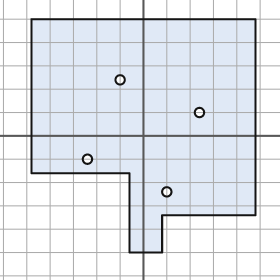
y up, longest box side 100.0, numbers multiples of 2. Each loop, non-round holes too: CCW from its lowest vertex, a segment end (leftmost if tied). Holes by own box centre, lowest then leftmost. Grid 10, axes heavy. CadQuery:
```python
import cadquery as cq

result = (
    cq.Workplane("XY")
    .moveTo(-6.0, -50.0)
    .lineTo(8.0, -50.0)
    .lineTo(8.0, -34.0)
    .lineTo(48.0, -34.0)
    .lineTo(48.0, 50.0)
    .lineTo(-48.0, 50.0)
    .lineTo(-48.0, -16.0)
    .lineTo(-6.0, -16.0)
    .close()
    .moveTo(10.0, -24.0)
    .circle(2.0)
    .moveTo(-24.0, -10.0)
    .circle(2.0)
    .moveTo(24.0, 10.0)
    .circle(2.0)
    .moveTo(-10.0, 24.0)
    .circle(2.0)
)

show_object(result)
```